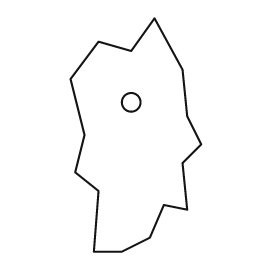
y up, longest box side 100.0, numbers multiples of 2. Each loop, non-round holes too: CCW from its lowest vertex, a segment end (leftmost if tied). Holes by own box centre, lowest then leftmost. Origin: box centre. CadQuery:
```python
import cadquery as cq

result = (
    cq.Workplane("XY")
    .moveTo(-18.0, -50.0)
    .lineTo(-6.0, -50.0)
    .lineTo(6.0, -44.0)
    .lineTo(12.0, -30.0)
    .lineTo(22.0, -32.0)
    .lineTo(20.0, -12.0)
    .lineTo(28.0, -4.0)
    .lineTo(22.0, 8.0)
    .lineTo(20.0, 28.0)
    .lineTo(8.0, 50.0)
    .lineTo(-2.0, 36.0)
    .lineTo(-16.0, 40.0)
    .lineTo(-28.0, 24.0)
    .lineTo(-22.0, 0.0)
    .lineTo(-26.0, -16.0)
    .lineTo(-16.0, -24.0)
    .close()
    .moveTo(-2.0, 14.0)
    .circle(4.0)
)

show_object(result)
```